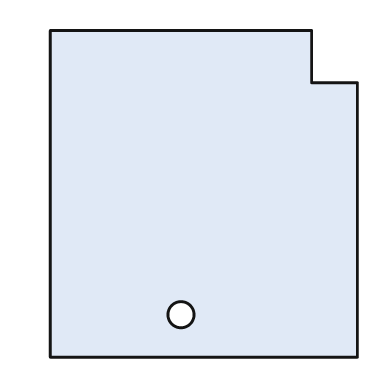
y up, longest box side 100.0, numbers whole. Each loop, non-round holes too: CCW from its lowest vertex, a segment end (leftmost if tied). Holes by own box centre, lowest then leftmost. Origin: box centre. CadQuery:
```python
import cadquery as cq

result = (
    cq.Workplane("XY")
    .moveTo(-47.0, -50.0)
    .lineTo(47.0, -50.0)
    .lineTo(47.0, 34.0)
    .lineTo(33.0, 34.0)
    .lineTo(33.0, 50.0)
    .lineTo(-47.0, 50.0)
    .close()
    .moveTo(-7.0, -37.0)
    .circle(4.0)
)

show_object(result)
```